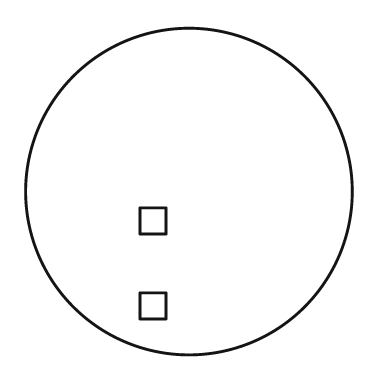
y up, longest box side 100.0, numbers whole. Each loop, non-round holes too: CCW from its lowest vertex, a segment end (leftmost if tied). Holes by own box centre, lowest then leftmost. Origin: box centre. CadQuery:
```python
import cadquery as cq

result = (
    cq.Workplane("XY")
    .moveTo(0.0, 0.0)
    .circle(50.0)
    .moveTo(-15.0, -39.0)
    .lineTo(-7.0, -39.0)
    .lineTo(-7.0, -31.0)
    .lineTo(-15.0, -31.0)
    .close()
    .moveTo(-15.0, -13.0)
    .lineTo(-7.0, -13.0)
    .lineTo(-7.0, -5.0)
    .lineTo(-15.0, -5.0)
    .close()
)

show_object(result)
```